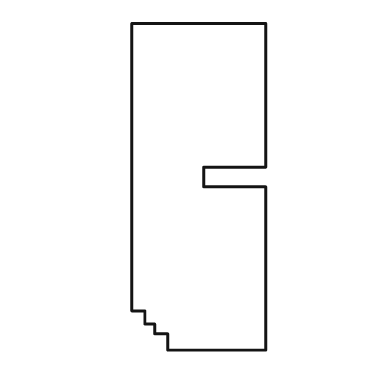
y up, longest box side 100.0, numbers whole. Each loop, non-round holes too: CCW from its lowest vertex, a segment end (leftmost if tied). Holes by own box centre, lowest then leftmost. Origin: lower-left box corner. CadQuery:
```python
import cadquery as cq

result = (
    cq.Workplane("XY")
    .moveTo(11.0, 0.0)
    .lineTo(41.0, 0.0)
    .lineTo(41.0, 50.0)
    .lineTo(22.0, 50.0)
    .lineTo(22.0, 56.0)
    .lineTo(41.0, 56.0)
    .lineTo(41.0, 100.0)
    .lineTo(0.0, 100.0)
    .lineTo(0.0, 12.0)
    .lineTo(4.0, 12.0)
    .lineTo(4.0, 8.0)
    .lineTo(7.0, 8.0)
    .lineTo(7.0, 5.0)
    .lineTo(11.0, 5.0)
    .close()
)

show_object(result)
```